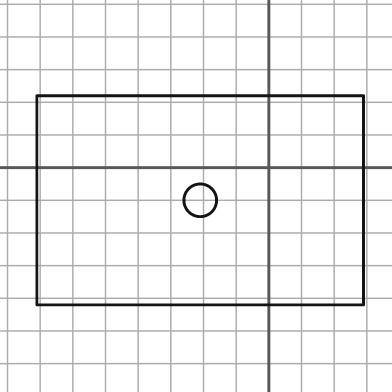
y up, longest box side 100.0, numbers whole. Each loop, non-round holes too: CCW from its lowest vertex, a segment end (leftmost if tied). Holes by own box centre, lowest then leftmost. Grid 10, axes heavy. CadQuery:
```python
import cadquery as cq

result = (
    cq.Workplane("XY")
    .moveTo(-71.0, -42.0)
    .lineTo(29.0, -42.0)
    .lineTo(29.0, 22.0)
    .lineTo(-71.0, 22.0)
    .close()
    .moveTo(-21.0, -10.0)
    .circle(5.0)
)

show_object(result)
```